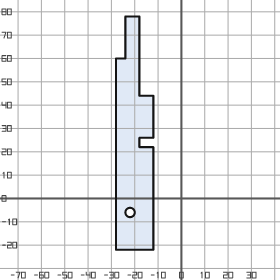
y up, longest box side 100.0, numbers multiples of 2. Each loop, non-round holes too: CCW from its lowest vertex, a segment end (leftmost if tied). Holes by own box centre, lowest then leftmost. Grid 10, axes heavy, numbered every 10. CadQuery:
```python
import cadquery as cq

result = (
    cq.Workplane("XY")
    .moveTo(-28.0, -22.0)
    .lineTo(-12.0, -22.0)
    .lineTo(-12.0, 22.0)
    .lineTo(-18.0, 22.0)
    .lineTo(-18.0, 26.0)
    .lineTo(-12.0, 26.0)
    .lineTo(-12.0, 44.0)
    .lineTo(-18.0, 44.0)
    .lineTo(-18.0, 78.0)
    .lineTo(-24.0, 78.0)
    .lineTo(-24.0, 60.0)
    .lineTo(-28.0, 60.0)
    .close()
    .moveTo(-22.0, -6.0)
    .circle(2.0)
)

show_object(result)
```